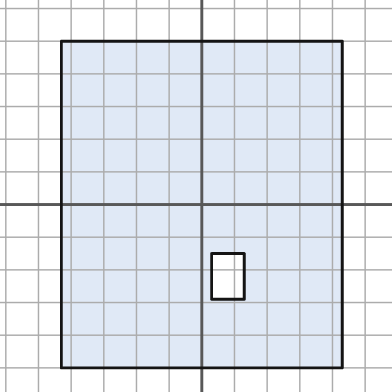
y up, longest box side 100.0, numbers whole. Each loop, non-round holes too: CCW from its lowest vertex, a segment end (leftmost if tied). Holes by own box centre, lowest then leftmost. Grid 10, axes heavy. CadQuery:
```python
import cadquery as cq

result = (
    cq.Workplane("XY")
    .moveTo(-43.0, -50.0)
    .lineTo(43.0, -50.0)
    .lineTo(43.0, 50.0)
    .lineTo(-43.0, 50.0)
    .close()
    .moveTo(3.0, -29.0)
    .lineTo(13.0, -29.0)
    .lineTo(13.0, -15.0)
    .lineTo(3.0, -15.0)
    .close()
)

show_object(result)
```